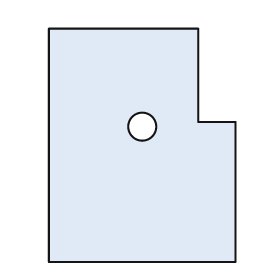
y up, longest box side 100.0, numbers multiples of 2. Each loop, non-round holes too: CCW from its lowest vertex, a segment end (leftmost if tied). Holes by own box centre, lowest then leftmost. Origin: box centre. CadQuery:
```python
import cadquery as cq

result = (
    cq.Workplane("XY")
    .moveTo(-40.0, -50.0)
    .lineTo(40.0, -50.0)
    .lineTo(40.0, 10.0)
    .lineTo(24.0, 10.0)
    .lineTo(24.0, 50.0)
    .lineTo(-40.0, 50.0)
    .close()
    .moveTo(0.0, 8.0)
    .circle(6.0)
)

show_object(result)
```